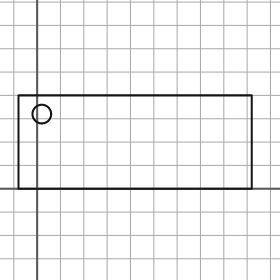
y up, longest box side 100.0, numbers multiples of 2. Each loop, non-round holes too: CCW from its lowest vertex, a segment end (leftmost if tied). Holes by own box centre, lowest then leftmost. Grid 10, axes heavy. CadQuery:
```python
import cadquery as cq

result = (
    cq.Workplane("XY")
    .moveTo(-8.0, 0.0)
    .lineTo(92.0, 0.0)
    .lineTo(92.0, 40.0)
    .lineTo(-8.0, 40.0)
    .close()
    .moveTo(2.0, 32.0)
    .circle(4.0)
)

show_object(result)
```